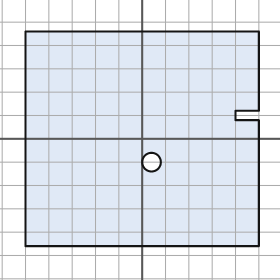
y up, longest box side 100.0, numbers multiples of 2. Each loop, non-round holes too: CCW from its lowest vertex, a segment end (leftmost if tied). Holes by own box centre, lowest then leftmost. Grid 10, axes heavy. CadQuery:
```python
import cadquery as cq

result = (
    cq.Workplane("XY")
    .moveTo(-50.0, -46.0)
    .lineTo(50.0, -46.0)
    .lineTo(50.0, 8.0)
    .lineTo(40.0, 8.0)
    .lineTo(40.0, 12.0)
    .lineTo(50.0, 12.0)
    .lineTo(50.0, 46.0)
    .lineTo(-50.0, 46.0)
    .close()
    .moveTo(4.0, -10.0)
    .circle(4.0)
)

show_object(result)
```